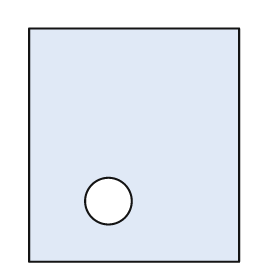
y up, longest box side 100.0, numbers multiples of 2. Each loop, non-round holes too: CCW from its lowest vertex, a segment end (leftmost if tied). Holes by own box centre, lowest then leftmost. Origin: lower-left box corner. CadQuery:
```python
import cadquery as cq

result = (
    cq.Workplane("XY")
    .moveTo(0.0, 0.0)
    .lineTo(90.0, 0.0)
    .lineTo(90.0, 100.0)
    .lineTo(0.0, 100.0)
    .close()
    .moveTo(34.0, 26.0)
    .circle(10.0)
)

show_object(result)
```